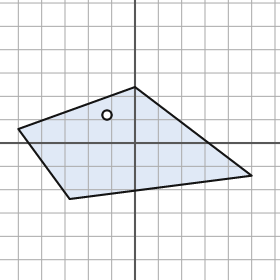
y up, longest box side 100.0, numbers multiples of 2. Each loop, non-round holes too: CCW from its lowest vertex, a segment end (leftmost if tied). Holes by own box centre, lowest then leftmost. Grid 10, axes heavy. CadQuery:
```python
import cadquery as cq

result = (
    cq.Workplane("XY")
    .moveTo(-28.0, -24.0)
    .lineTo(50.0, -14.0)
    .lineTo(0.0, 24.0)
    .lineTo(-50.0, 6.0)
    .close()
    .moveTo(-12.0, 12.0)
    .circle(2.0)
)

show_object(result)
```